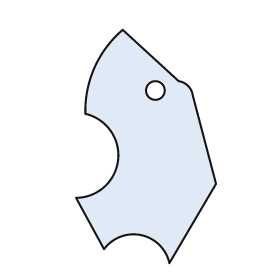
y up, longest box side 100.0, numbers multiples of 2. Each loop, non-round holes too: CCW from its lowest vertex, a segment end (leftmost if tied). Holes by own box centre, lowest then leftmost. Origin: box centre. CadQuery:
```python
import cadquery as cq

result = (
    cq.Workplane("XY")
    .moveTo(10.0, -50.0)
    .lineTo(30.0, -16.0)
    .lineTo(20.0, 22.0)
    .threePointArc((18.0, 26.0), (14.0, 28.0))
    .lineTo(-10.0, 50.0)
    .threePointArc((-22.0, 34.0), (-26.0, 14.0))
    .threePointArc((-12.0, -6.0), (-30.0, -22.0))
    .lineTo(-18.0, -44.0)
    .threePointArc((-2.0, -38.0), (10.0, -50.0))
    .close()
    .moveTo(4.0, 24.0)
    .circle(4.0)
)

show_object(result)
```